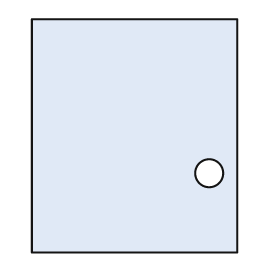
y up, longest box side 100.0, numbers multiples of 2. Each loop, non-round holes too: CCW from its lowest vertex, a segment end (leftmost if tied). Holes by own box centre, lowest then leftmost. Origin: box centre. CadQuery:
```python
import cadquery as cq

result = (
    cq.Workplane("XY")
    .moveTo(-44.0, -50.0)
    .lineTo(44.0, -50.0)
    .lineTo(44.0, 50.0)
    .lineTo(-44.0, 50.0)
    .close()
    .moveTo(32.0, -16.0)
    .circle(6.0)
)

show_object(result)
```